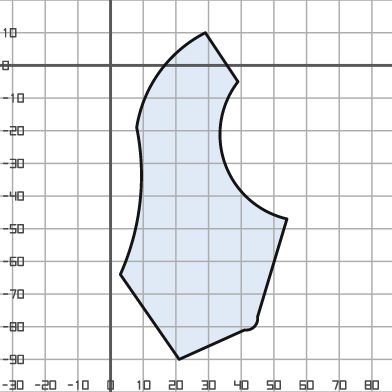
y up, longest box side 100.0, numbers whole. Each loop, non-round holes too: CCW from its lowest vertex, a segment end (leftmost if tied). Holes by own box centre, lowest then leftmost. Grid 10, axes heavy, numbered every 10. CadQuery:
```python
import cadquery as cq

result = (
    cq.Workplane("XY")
    .moveTo(21.0, -90.0)
    .lineTo(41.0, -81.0)
    .threePointArc((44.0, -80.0), (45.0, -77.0))
    .lineTo(54.0, -47.0)
    .threePointArc((35.0, -30.0), (39.0, -5.0))
    .lineTo(29.0, 10.0)
    .threePointArc((15.0, -2.0), (8.0, -19.0))
    .threePointArc((9.0, -42.0), (3.0, -64.0))
    .close()
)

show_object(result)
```